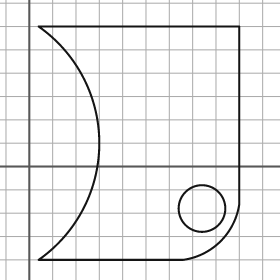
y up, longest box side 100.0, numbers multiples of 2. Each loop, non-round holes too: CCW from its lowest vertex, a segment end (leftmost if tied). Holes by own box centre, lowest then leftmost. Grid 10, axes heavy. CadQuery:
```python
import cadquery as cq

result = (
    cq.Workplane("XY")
    .moveTo(4.0, -40.0)
    .lineTo(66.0, -40.0)
    .threePointArc((82.0, -32.0), (90.0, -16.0))
    .lineTo(90.0, 60.0)
    .lineTo(4.0, 60.0)
    .threePointArc((30.0, 10.0), (4.0, -40.0))
    .close()
    .moveTo(74.0, -18.0)
    .circle(10.0)
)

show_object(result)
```